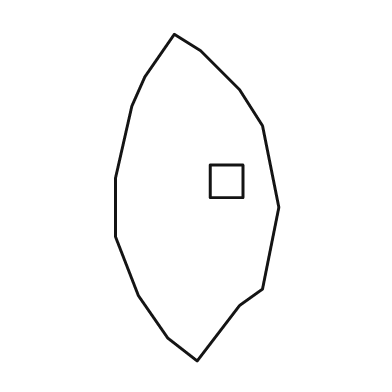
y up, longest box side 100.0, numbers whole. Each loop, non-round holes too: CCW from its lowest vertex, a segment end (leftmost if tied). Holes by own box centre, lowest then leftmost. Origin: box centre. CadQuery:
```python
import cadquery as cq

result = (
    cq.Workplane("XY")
    .moveTo(0.0, -50.0)
    .lineTo(13.0, -33.0)
    .lineTo(20.0, -28.0)
    .lineTo(25.0, -3.0)
    .lineTo(20.0, 22.0)
    .lineTo(13.0, 33.0)
    .lineTo(1.0, 45.0)
    .lineTo(-7.0, 50.0)
    .lineTo(-16.0, 37.0)
    .lineTo(-20.0, 28.0)
    .lineTo(-25.0, 6.0)
    .lineTo(-25.0, -12.0)
    .lineTo(-18.0, -30.0)
    .lineTo(-9.0, -43.0)
    .close()
    .moveTo(4.0, 0.0)
    .lineTo(14.0, 0.0)
    .lineTo(14.0, 10.0)
    .lineTo(4.0, 10.0)
    .close()
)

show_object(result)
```